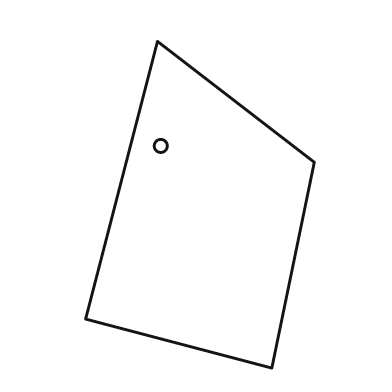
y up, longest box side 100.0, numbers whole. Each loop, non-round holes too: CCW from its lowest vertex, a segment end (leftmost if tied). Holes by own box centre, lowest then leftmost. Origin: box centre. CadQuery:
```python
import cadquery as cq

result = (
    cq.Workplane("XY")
    .moveTo(22.0, -50.0)
    .lineTo(35.0, 13.0)
    .lineTo(-13.0, 50.0)
    .lineTo(-35.0, -35.0)
    .close()
    .moveTo(-12.0, 18.0)
    .circle(2.0)
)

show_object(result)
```